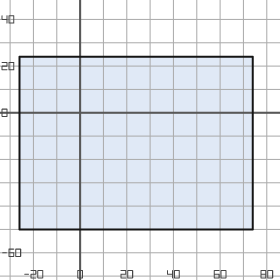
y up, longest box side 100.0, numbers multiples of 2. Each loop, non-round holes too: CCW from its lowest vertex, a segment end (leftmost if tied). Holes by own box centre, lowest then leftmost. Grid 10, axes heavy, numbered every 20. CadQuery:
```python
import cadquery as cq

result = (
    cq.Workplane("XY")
    .moveTo(-26.0, -50.0)
    .lineTo(74.0, -50.0)
    .lineTo(74.0, 24.0)
    .lineTo(-26.0, 24.0)
    .close()
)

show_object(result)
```